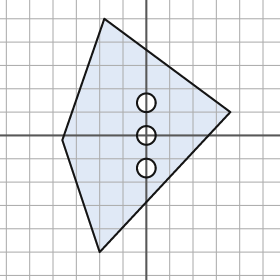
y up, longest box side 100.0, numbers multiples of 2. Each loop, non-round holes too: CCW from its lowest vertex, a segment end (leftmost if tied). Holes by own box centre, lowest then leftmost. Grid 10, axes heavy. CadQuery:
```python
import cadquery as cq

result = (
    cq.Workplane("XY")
    .moveTo(-20.0, -50.0)
    .lineTo(36.0, 10.0)
    .lineTo(-18.0, 50.0)
    .lineTo(-36.0, -2.0)
    .close()
    .moveTo(0.0, -14.0)
    .circle(4.0)
    .moveTo(0.0, 0.0)
    .circle(4.0)
    .moveTo(0.0, 14.0)
    .circle(4.0)
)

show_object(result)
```